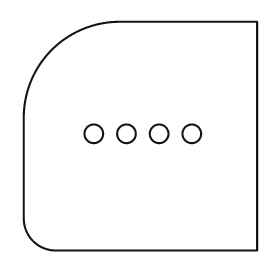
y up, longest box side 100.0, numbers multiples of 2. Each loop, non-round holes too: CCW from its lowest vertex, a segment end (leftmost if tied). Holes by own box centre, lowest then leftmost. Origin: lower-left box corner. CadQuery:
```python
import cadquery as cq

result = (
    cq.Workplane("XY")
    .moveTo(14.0, 0.0)
    .lineTo(100.0, 0.0)
    .lineTo(100.0, 98.0)
    .lineTo(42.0, 98.0)
    .threePointArc((12.0, 86.0), (0.0, 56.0))
    .lineTo(0.0, 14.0)
    .threePointArc((4.0, 4.0), (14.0, 0.0))
    .close()
    .moveTo(30.0, 50.0)
    .circle(4.0)
    .moveTo(44.0, 50.0)
    .circle(4.0)
    .moveTo(58.0, 50.0)
    .circle(4.0)
    .moveTo(72.0, 50.0)
    .circle(4.0)
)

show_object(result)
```